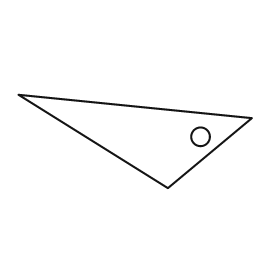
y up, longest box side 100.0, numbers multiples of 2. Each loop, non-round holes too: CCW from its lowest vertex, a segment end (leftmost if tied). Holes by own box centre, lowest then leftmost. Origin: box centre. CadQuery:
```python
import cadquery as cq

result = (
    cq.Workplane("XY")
    .moveTo(14.0, -20.0)
    .lineTo(50.0, 10.0)
    .lineTo(-50.0, 20.0)
    .close()
    .moveTo(28.0, 2.0)
    .circle(4.0)
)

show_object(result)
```